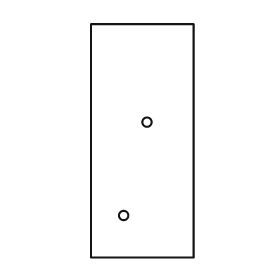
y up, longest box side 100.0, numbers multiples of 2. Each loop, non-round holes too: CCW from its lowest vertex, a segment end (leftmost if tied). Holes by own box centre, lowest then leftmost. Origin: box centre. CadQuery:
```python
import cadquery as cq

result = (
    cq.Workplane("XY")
    .moveTo(-22.0, -50.0)
    .lineTo(22.0, -50.0)
    .lineTo(22.0, 50.0)
    .lineTo(-22.0, 50.0)
    .close()
    .moveTo(-8.0, -32.0)
    .circle(2.0)
    .moveTo(2.0, 8.0)
    .circle(2.0)
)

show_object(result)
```